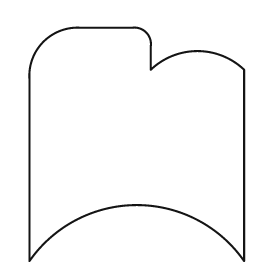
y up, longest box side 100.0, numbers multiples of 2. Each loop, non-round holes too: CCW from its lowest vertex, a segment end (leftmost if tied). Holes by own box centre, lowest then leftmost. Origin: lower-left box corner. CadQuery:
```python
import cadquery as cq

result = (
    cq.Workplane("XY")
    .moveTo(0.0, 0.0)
    .threePointArc((46.0, 24.0), (92.0, 0.0))
    .lineTo(92.0, 82.0)
    .threePointArc((72.0, 90.0), (52.0, 82.0))
    .lineTo(52.0, 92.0)
    .threePointArc((50.0, 98.0), (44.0, 100.0))
    .lineTo(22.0, 100.0)
    .threePointArc((6.0, 94.0), (0.0, 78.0))
    .close()
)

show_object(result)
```